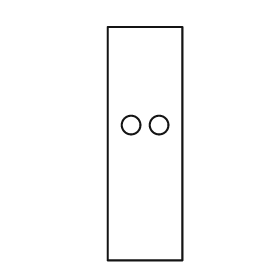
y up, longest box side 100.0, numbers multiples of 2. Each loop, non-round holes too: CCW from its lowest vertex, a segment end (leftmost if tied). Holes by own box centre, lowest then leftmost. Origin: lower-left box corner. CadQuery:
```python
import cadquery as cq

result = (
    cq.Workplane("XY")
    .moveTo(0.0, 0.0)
    .lineTo(32.0, 0.0)
    .lineTo(32.0, 100.0)
    .lineTo(0.0, 100.0)
    .close()
    .moveTo(10.0, 58.0)
    .circle(4.0)
    .moveTo(22.0, 58.0)
    .circle(4.0)
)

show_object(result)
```